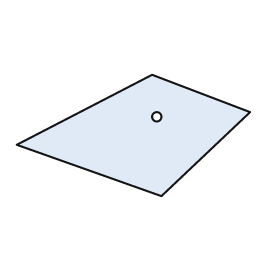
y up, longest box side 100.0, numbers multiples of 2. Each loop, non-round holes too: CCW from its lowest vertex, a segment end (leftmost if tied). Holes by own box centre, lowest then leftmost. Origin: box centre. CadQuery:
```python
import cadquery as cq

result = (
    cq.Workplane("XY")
    .moveTo(12.0, -26.0)
    .lineTo(50.0, 10.0)
    .lineTo(8.0, 26.0)
    .lineTo(-50.0, -4.0)
    .close()
    .moveTo(10.0, 8.0)
    .circle(2.0)
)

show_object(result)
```